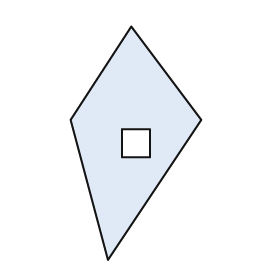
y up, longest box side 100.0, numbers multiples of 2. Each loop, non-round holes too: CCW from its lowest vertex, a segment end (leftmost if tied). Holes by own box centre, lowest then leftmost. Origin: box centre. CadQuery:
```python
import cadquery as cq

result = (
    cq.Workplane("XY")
    .moveTo(-12.0, -50.0)
    .lineTo(28.0, 10.0)
    .lineTo(-2.0, 50.0)
    .lineTo(-28.0, 10.0)
    .close()
    .moveTo(-6.0, -6.0)
    .lineTo(6.0, -6.0)
    .lineTo(6.0, 6.0)
    .lineTo(-6.0, 6.0)
    .close()
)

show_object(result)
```